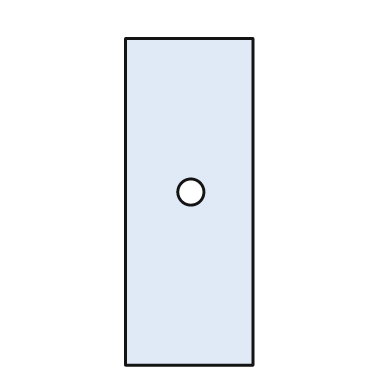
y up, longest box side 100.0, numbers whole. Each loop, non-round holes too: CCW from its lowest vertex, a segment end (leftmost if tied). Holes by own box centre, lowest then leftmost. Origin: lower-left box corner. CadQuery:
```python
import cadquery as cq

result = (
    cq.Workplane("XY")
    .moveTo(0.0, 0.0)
    .lineTo(39.0, 0.0)
    .lineTo(39.0, 100.0)
    .lineTo(0.0, 100.0)
    .close()
    .moveTo(20.0, 53.0)
    .circle(4.0)
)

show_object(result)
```